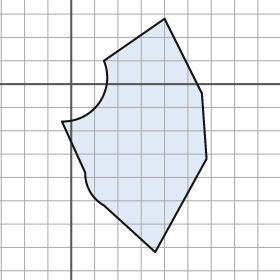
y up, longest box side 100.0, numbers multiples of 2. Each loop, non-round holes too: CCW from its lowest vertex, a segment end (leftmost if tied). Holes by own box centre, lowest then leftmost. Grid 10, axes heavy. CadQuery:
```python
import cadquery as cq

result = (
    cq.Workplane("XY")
    .moveTo(36.0, -72.0)
    .lineTo(58.0, -32.0)
    .lineTo(56.0, -4.0)
    .lineTo(40.0, 28.0)
    .lineTo(14.0, 10.0)
    .threePointArc((12.0, -8.0), (-4.0, -16.0))
    .lineTo(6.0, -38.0)
    .threePointArc((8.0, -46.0), (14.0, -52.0))
    .close()
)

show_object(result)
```